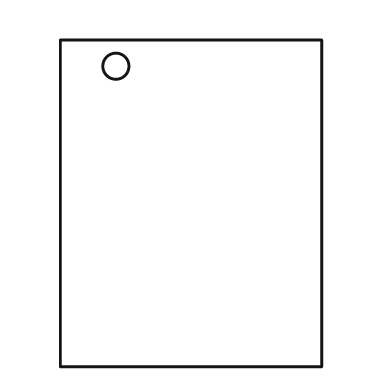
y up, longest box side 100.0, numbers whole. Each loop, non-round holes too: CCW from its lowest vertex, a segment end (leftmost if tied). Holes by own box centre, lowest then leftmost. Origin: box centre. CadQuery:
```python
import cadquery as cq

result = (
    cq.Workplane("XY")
    .moveTo(-40.0, -50.0)
    .lineTo(40.0, -50.0)
    .lineTo(40.0, 50.0)
    .lineTo(-40.0, 50.0)
    .close()
    .moveTo(-23.0, 42.0)
    .circle(4.0)
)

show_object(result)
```